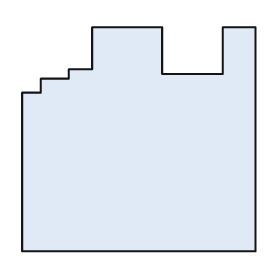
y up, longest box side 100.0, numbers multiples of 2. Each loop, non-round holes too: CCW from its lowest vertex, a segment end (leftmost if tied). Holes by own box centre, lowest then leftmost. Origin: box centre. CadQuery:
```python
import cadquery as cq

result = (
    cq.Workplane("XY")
    .moveTo(-50.0, -48.0)
    .lineTo(50.0, -48.0)
    .lineTo(50.0, 48.0)
    .lineTo(36.0, 48.0)
    .lineTo(36.0, 28.0)
    .lineTo(10.0, 28.0)
    .lineTo(10.0, 48.0)
    .lineTo(-20.0, 48.0)
    .lineTo(-20.0, 30.0)
    .lineTo(-30.0, 30.0)
    .lineTo(-30.0, 26.0)
    .lineTo(-42.0, 26.0)
    .lineTo(-42.0, 20.0)
    .lineTo(-50.0, 20.0)
    .close()
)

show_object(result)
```